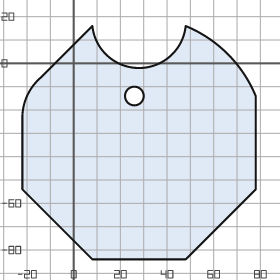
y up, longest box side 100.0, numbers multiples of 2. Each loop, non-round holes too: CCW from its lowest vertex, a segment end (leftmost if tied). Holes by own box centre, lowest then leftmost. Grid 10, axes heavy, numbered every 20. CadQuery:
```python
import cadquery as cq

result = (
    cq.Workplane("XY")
    .moveTo(8.0, -84.0)
    .lineTo(48.0, -84.0)
    .lineTo(78.0, -54.0)
    .lineTo(78.0, -14.0)
    .threePointArc((66.0, 4.0), (48.0, 16.0))
    .threePointArc((28.0, -2.0), (8.0, 16.0))
    .lineTo(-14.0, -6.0)
    .threePointArc((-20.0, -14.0), (-22.0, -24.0))
    .lineTo(-22.0, -54.0)
    .close()
    .moveTo(26.0, -14.0)
    .circle(4.0)
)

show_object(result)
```